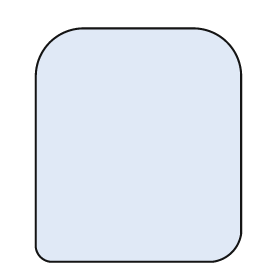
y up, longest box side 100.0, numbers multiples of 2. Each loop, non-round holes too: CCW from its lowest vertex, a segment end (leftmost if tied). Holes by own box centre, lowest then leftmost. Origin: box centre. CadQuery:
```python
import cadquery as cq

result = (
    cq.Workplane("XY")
    .moveTo(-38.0, -50.0)
    .lineTo(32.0, -50.0)
    .threePointArc((40.0, -46.0), (44.0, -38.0))
    .lineTo(44.0, 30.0)
    .threePointArc((38.0, 44.0), (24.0, 50.0))
    .lineTo(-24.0, 50.0)
    .threePointArc((-38.0, 44.0), (-44.0, 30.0))
    .lineTo(-44.0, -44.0)
    .threePointArc((-42.0, -48.0), (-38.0, -50.0))
    .close()
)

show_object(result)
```